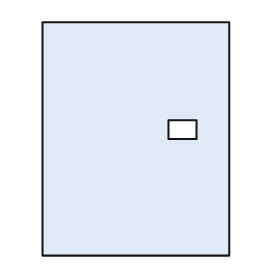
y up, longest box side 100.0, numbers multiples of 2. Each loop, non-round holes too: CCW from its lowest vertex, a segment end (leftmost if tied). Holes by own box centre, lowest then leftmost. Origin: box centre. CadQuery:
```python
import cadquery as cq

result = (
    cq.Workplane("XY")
    .moveTo(-40.0, -50.0)
    .lineTo(40.0, -50.0)
    .lineTo(40.0, 50.0)
    .lineTo(-40.0, 50.0)
    .close()
    .moveTo(14.0, 0.0)
    .lineTo(26.0, 0.0)
    .lineTo(26.0, 8.0)
    .lineTo(14.0, 8.0)
    .close()
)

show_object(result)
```